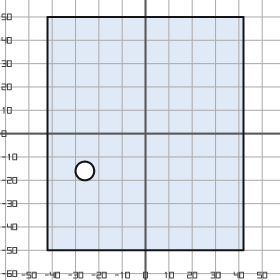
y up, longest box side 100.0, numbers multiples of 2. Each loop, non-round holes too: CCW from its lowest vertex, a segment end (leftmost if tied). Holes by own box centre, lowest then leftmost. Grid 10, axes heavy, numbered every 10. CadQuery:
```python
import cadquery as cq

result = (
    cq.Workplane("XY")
    .moveTo(-42.0, -50.0)
    .lineTo(42.0, -50.0)
    .lineTo(42.0, 50.0)
    .lineTo(-42.0, 50.0)
    .close()
    .moveTo(-26.0, -16.0)
    .circle(4.0)
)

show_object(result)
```